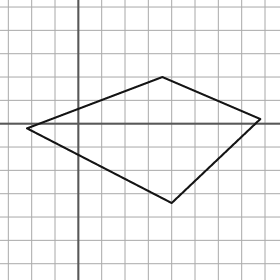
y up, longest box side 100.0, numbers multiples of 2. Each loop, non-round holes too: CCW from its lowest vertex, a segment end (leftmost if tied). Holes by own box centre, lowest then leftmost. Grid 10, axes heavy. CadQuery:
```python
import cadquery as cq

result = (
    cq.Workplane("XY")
    .moveTo(40.0, -34.0)
    .lineTo(78.0, 2.0)
    .lineTo(36.0, 20.0)
    .lineTo(-22.0, -2.0)
    .close()
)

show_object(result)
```